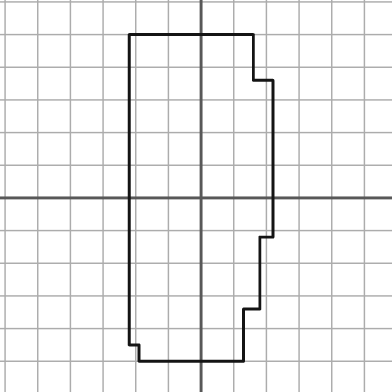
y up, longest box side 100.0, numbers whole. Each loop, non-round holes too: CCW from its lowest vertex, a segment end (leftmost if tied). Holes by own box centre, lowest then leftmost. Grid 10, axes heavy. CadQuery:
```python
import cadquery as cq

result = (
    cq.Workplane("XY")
    .moveTo(-19.0, -50.0)
    .lineTo(13.0, -50.0)
    .lineTo(13.0, -34.0)
    .lineTo(18.0, -34.0)
    .lineTo(18.0, -12.0)
    .lineTo(22.0, -12.0)
    .lineTo(22.0, 36.0)
    .lineTo(16.0, 36.0)
    .lineTo(16.0, 50.0)
    .lineTo(-22.0, 50.0)
    .lineTo(-22.0, -45.0)
    .lineTo(-19.0, -45.0)
    .close()
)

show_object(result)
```